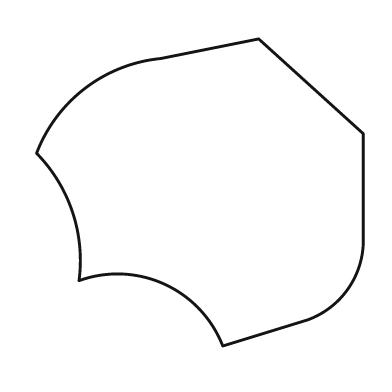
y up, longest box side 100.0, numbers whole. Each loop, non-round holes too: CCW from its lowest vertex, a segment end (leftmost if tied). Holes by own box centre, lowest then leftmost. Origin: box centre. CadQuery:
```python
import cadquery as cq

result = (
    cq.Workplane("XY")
    .moveTo(7.0, -47.0)
    .lineTo(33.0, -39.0)
    .threePointArc((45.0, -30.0), (50.0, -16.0))
    .lineTo(50.0, 18.0)
    .lineTo(18.0, 47.0)
    .lineTo(-12.0, 41.0)
    .threePointArc((-35.0, 32.0), (-50.0, 12.0))
    .threePointArc((-39.0, -6.0), (-37.0, -27.0))
    .threePointArc((-11.0, -28.0), (7.0, -47.0))
    .close()
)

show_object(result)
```